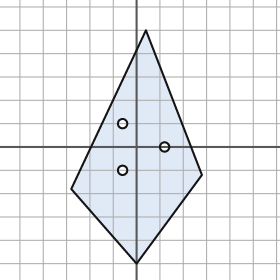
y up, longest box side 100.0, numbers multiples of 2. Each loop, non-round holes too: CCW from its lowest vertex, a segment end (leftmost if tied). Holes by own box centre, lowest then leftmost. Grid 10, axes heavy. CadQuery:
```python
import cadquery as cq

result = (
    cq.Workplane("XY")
    .moveTo(0.0, -50.0)
    .lineTo(28.0, -12.0)
    .lineTo(4.0, 50.0)
    .lineTo(-28.0, -18.0)
    .close()
    .moveTo(-6.0, -10.0)
    .circle(2.0)
    .moveTo(12.0, 0.0)
    .circle(2.0)
    .moveTo(-6.0, 10.0)
    .circle(2.0)
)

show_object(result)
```